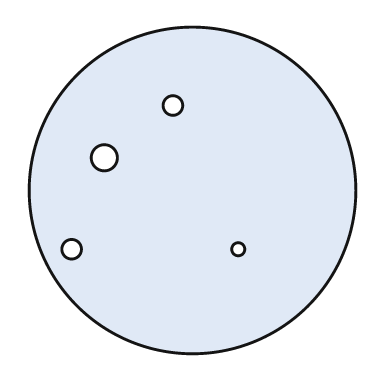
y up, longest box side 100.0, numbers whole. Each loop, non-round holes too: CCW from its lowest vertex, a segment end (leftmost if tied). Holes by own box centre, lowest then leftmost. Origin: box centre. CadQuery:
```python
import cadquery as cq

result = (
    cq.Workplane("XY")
    .moveTo(0.0, 0.0)
    .circle(50.0)
    .moveTo(-37.0, -18.0)
    .circle(3.0)
    .moveTo(14.0, -18.0)
    .circle(2.0)
    .moveTo(-27.0, 10.0)
    .circle(4.0)
    .moveTo(-6.0, 26.0)
    .circle(3.0)
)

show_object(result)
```